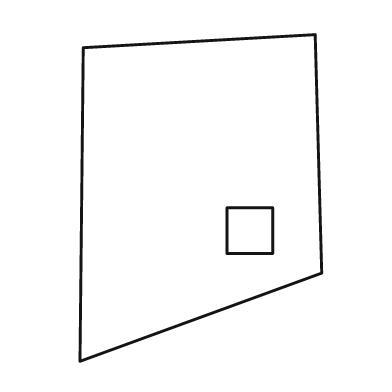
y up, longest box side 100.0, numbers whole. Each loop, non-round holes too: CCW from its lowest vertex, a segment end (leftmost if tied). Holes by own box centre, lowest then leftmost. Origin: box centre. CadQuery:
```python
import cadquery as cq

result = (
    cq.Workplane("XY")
    .moveTo(-37.0, -50.0)
    .lineTo(37.0, -23.0)
    .lineTo(35.0, 50.0)
    .lineTo(-36.0, 46.0)
    .close()
    .moveTo(8.0, -17.0)
    .lineTo(22.0, -17.0)
    .lineTo(22.0, -3.0)
    .lineTo(8.0, -3.0)
    .close()
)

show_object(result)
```